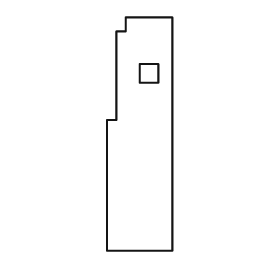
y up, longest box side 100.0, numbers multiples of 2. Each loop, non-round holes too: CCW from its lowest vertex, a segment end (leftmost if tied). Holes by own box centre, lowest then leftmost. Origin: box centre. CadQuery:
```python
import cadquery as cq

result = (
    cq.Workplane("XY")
    .moveTo(-14.0, -50.0)
    .lineTo(14.0, -50.0)
    .lineTo(14.0, 50.0)
    .lineTo(-6.0, 50.0)
    .lineTo(-6.0, 44.0)
    .lineTo(-10.0, 44.0)
    .lineTo(-10.0, 6.0)
    .lineTo(-14.0, 6.0)
    .close()
    .moveTo(0.0, 22.0)
    .lineTo(8.0, 22.0)
    .lineTo(8.0, 30.0)
    .lineTo(0.0, 30.0)
    .close()
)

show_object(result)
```